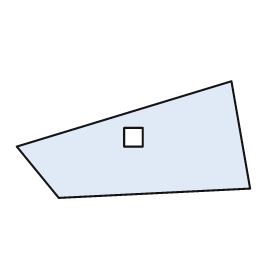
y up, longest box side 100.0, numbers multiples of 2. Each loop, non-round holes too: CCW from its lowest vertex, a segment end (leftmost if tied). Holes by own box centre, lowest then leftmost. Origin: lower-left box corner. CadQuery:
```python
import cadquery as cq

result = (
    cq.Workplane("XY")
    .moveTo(18.0, 0.0)
    .lineTo(100.0, 4.0)
    .lineTo(92.0, 50.0)
    .lineTo(0.0, 22.0)
    .close()
    .moveTo(46.0, 22.0)
    .lineTo(54.0, 22.0)
    .lineTo(54.0, 30.0)
    .lineTo(46.0, 30.0)
    .close()
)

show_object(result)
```